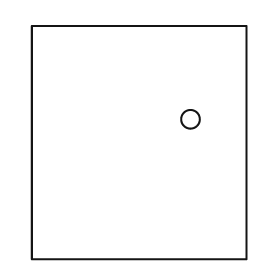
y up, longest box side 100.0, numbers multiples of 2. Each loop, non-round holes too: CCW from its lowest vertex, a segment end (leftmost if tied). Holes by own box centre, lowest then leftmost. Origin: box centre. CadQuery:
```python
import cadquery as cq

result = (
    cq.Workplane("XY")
    .moveTo(-46.0, -50.0)
    .lineTo(46.0, -50.0)
    .lineTo(46.0, 50.0)
    .lineTo(-46.0, 50.0)
    .close()
    .moveTo(22.0, 10.0)
    .circle(4.0)
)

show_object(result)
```